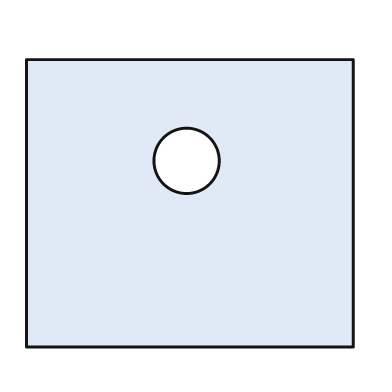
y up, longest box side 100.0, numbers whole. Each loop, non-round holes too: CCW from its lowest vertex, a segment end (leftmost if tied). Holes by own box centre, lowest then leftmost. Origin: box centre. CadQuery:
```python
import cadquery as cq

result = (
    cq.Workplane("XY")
    .moveTo(-50.0, -44.0)
    .lineTo(50.0, -44.0)
    .lineTo(50.0, 44.0)
    .lineTo(-50.0, 44.0)
    .close()
    .moveTo(-1.0, 13.0)
    .circle(10.0)
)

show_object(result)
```